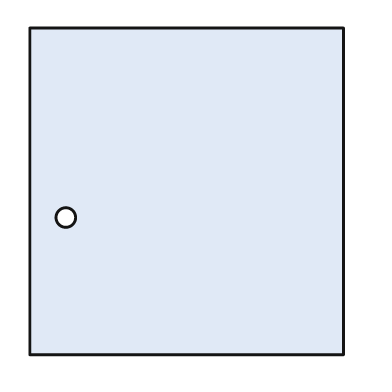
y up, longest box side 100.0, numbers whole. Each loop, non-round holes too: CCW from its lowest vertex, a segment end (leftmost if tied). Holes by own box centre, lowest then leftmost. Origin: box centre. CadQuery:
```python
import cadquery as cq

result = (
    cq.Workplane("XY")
    .moveTo(-48.0, -50.0)
    .lineTo(48.0, -50.0)
    .lineTo(48.0, 50.0)
    .lineTo(-48.0, 50.0)
    .close()
    .moveTo(-37.0, -8.0)
    .circle(3.0)
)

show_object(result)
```